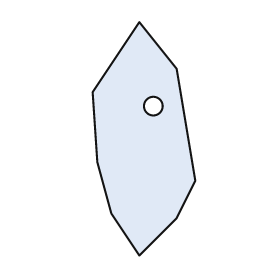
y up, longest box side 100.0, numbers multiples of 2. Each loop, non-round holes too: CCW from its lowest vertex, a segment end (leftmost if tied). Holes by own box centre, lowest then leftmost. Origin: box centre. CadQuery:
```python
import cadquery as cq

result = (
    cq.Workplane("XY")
    .moveTo(-2.0, -50.0)
    .lineTo(14.0, -34.0)
    .lineTo(22.0, -18.0)
    .lineTo(14.0, 30.0)
    .lineTo(-2.0, 50.0)
    .lineTo(-22.0, 20.0)
    .lineTo(-20.0, -10.0)
    .lineTo(-14.0, -32.0)
    .close()
    .moveTo(4.0, 14.0)
    .circle(4.0)
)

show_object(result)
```